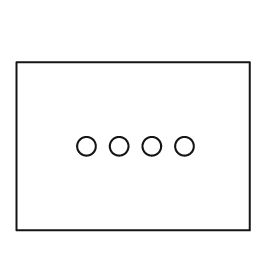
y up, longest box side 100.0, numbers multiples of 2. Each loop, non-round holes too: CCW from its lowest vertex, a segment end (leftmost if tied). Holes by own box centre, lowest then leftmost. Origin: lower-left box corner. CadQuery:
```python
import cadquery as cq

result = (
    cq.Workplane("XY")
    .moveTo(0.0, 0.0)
    .lineTo(100.0, 0.0)
    .lineTo(100.0, 72.0)
    .lineTo(0.0, 72.0)
    .close()
    .moveTo(30.0, 36.0)
    .circle(4.0)
    .moveTo(44.0, 36.0)
    .circle(4.0)
    .moveTo(58.0, 36.0)
    .circle(4.0)
    .moveTo(72.0, 36.0)
    .circle(4.0)
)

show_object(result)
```